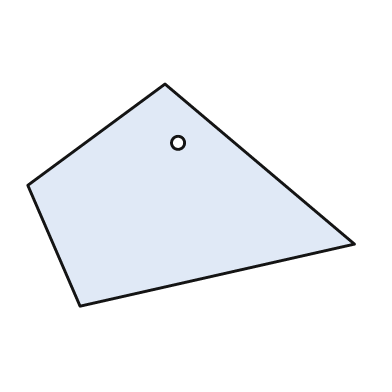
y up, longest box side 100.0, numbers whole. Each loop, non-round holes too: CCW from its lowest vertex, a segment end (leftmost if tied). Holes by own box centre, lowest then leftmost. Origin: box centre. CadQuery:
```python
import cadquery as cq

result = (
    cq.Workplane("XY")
    .moveTo(-34.0, -34.0)
    .lineTo(50.0, -15.0)
    .lineTo(-8.0, 34.0)
    .lineTo(-50.0, 3.0)
    .close()
    .moveTo(-4.0, 16.0)
    .circle(2.0)
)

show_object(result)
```